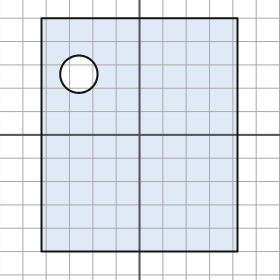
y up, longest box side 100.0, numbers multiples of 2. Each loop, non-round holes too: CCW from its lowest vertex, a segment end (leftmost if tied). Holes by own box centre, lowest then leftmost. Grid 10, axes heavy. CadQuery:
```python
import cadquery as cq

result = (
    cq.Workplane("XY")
    .moveTo(-42.0, -50.0)
    .lineTo(42.0, -50.0)
    .lineTo(42.0, 50.0)
    .lineTo(-42.0, 50.0)
    .close()
    .moveTo(-26.0, 26.0)
    .circle(8.0)
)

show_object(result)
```